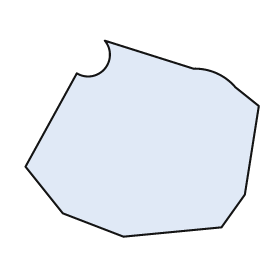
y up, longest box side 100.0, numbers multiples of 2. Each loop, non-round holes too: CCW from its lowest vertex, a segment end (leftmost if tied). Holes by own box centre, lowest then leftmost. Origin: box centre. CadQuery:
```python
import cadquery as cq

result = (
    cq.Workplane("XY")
    .moveTo(-8.0, -42.0)
    .lineTo(34.0, -38.0)
    .lineTo(44.0, -24.0)
    .lineTo(50.0, 14.0)
    .lineTo(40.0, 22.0)
    .threePointArc((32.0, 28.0), (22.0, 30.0))
    .lineTo(-16.0, 42.0)
    .threePointArc((-16.0, 30.0), (-28.0, 28.0))
    .lineTo(-50.0, -12.0)
    .lineTo(-34.0, -32.0)
    .close()
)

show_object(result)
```